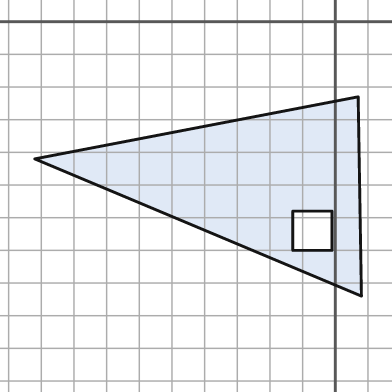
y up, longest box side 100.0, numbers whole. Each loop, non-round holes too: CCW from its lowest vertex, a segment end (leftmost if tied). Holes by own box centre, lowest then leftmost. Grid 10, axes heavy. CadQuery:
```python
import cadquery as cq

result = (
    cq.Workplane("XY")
    .moveTo(8.0, -84.0)
    .lineTo(7.0, -23.0)
    .lineTo(-92.0, -42.0)
    .close()
    .moveTo(-13.0, -70.0)
    .lineTo(-1.0, -70.0)
    .lineTo(-1.0, -58.0)
    .lineTo(-13.0, -58.0)
    .close()
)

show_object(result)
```